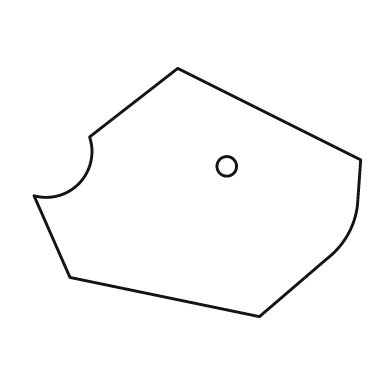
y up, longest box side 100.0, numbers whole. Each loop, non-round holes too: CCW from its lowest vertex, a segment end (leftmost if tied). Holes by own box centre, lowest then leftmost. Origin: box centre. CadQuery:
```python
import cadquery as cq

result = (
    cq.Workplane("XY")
    .moveTo(19.0, -38.0)
    .lineTo(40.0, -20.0)
    .threePointArc((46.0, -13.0), (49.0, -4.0))
    .lineTo(50.0, 10.0)
    .lineTo(-6.0, 38.0)
    .lineTo(-33.0, 17.0)
    .threePointArc((-36.0, 3.0), (-50.0, -1.0))
    .lineTo(-39.0, -26.0)
    .close()
    .moveTo(9.0, 8.0)
    .circle(3.0)
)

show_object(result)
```